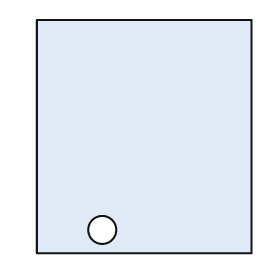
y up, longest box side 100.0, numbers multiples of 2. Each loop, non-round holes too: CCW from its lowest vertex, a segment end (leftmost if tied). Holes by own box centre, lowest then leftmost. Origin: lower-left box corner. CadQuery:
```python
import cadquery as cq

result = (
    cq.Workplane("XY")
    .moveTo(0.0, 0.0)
    .lineTo(92.0, 0.0)
    .lineTo(92.0, 100.0)
    .lineTo(0.0, 100.0)
    .close()
    .moveTo(28.0, 10.0)
    .circle(6.0)
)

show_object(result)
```